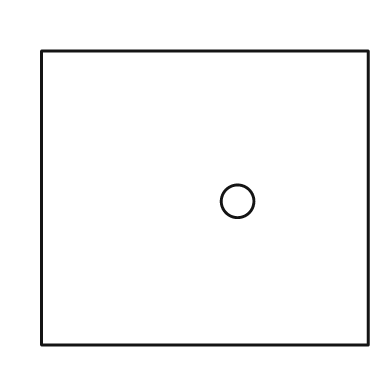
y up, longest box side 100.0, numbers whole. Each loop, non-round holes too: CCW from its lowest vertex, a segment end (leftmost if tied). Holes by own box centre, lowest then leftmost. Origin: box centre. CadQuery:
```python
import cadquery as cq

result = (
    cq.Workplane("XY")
    .moveTo(-50.0, -45.0)
    .lineTo(50.0, -45.0)
    .lineTo(50.0, 45.0)
    .lineTo(-50.0, 45.0)
    .close()
    .moveTo(10.0, -1.0)
    .circle(5.0)
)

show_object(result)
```